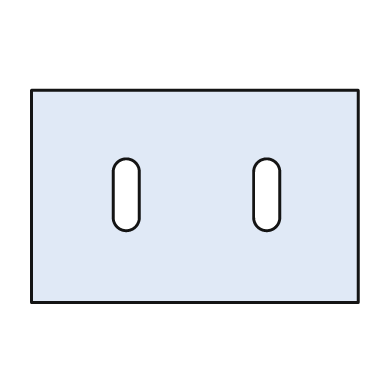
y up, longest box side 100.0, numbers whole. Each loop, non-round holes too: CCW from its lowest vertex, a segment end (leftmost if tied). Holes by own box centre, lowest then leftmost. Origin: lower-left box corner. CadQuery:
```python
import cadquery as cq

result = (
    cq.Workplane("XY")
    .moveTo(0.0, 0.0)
    .lineTo(100.0, 0.0)
    .lineTo(100.0, 65.0)
    .lineTo(0.0, 65.0)
    .close()
    .moveTo(25.0, 26.0)
    .threePointArc((29.0, 22.0), (33.0, 26.0))
    .lineTo(33.0, 40.0)
    .threePointArc((29.0, 44.0), (25.0, 40.0))
    .close()
    .moveTo(68.0, 26.0)
    .threePointArc((72.0, 22.0), (76.0, 26.0))
    .lineTo(76.0, 40.0)
    .threePointArc((72.0, 44.0), (68.0, 40.0))
    .close()
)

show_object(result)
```